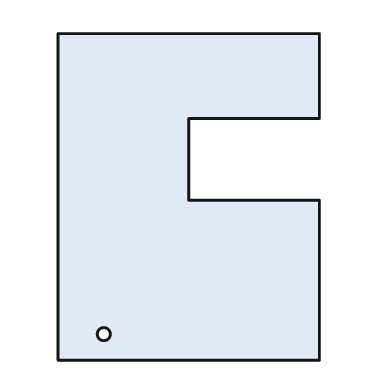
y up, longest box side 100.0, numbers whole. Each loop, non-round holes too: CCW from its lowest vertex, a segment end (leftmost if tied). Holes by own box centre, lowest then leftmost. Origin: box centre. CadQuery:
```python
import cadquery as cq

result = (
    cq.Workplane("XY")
    .moveTo(-40.0, -50.0)
    .lineTo(40.0, -50.0)
    .lineTo(40.0, -1.0)
    .lineTo(0.0, -1.0)
    .lineTo(0.0, 24.0)
    .lineTo(40.0, 24.0)
    .lineTo(40.0, 50.0)
    .lineTo(-40.0, 50.0)
    .close()
    .moveTo(-26.0, -42.0)
    .circle(2.0)
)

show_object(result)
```